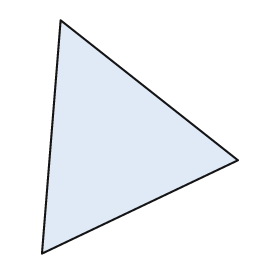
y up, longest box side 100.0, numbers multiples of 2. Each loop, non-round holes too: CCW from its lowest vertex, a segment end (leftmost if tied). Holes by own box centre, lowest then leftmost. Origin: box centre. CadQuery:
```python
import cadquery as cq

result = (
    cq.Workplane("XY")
    .moveTo(-42.0, -50.0)
    .lineTo(42.0, -10.0)
    .lineTo(-34.0, 50.0)
    .close()
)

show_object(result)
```